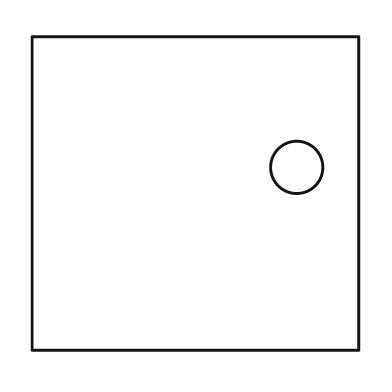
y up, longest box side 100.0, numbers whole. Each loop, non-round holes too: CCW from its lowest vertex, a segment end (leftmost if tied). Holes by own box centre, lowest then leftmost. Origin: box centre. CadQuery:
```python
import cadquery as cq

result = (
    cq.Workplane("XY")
    .moveTo(-50.0, -48.0)
    .lineTo(50.0, -48.0)
    .lineTo(50.0, 48.0)
    .lineTo(-50.0, 48.0)
    .close()
    .moveTo(31.0, 8.0)
    .circle(8.0)
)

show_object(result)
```